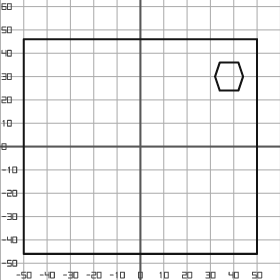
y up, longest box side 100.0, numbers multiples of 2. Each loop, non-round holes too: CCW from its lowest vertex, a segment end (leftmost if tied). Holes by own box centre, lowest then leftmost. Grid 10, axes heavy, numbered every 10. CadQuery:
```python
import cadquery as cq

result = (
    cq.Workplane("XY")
    .moveTo(-50.0, -46.0)
    .lineTo(50.0, -46.0)
    .lineTo(50.0, 46.0)
    .lineTo(-50.0, 46.0)
    .close()
    .moveTo(34.0, 24.0)
    .lineTo(42.0, 24.0)
    .lineTo(44.0, 30.0)
    .lineTo(42.0, 36.0)
    .lineTo(34.0, 36.0)
    .lineTo(32.0, 30.0)
    .close()
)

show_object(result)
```